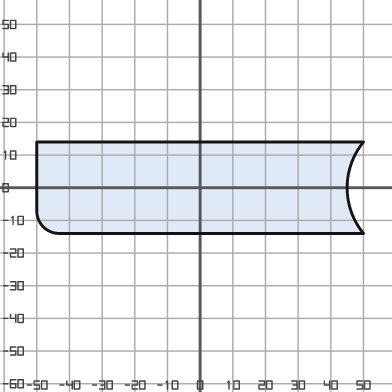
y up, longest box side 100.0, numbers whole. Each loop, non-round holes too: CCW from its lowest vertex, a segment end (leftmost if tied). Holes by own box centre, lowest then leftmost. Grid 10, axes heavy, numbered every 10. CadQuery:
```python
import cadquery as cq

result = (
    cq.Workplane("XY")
    .moveTo(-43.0, -14.0)
    .lineTo(50.0, -14.0)
    .threePointArc((45.0, 0.0), (50.0, 14.0))
    .lineTo(-50.0, 14.0)
    .lineTo(-50.0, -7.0)
    .threePointArc((-48.0, -12.0), (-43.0, -14.0))
    .close()
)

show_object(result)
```